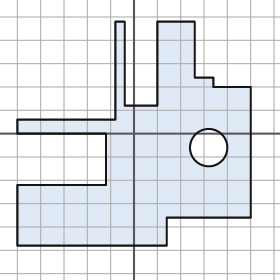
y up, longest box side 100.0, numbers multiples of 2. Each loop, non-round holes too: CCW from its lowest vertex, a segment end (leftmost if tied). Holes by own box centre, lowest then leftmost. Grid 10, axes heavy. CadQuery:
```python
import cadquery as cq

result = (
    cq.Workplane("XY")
    .moveTo(-50.0, -48.0)
    .lineTo(14.0, -48.0)
    .lineTo(14.0, -36.0)
    .lineTo(50.0, -36.0)
    .lineTo(50.0, 20.0)
    .lineTo(34.0, 20.0)
    .lineTo(34.0, 24.0)
    .lineTo(26.0, 24.0)
    .lineTo(26.0, 48.0)
    .lineTo(10.0, 48.0)
    .lineTo(10.0, 12.0)
    .lineTo(-4.0, 12.0)
    .lineTo(-4.0, 48.0)
    .lineTo(-8.0, 48.0)
    .lineTo(-8.0, 6.0)
    .lineTo(-50.0, 6.0)
    .lineTo(-50.0, 0.0)
    .lineTo(-12.0, 0.0)
    .lineTo(-12.0, -22.0)
    .lineTo(-50.0, -22.0)
    .close()
    .moveTo(32.0, -6.0)
    .circle(8.0)
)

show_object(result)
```